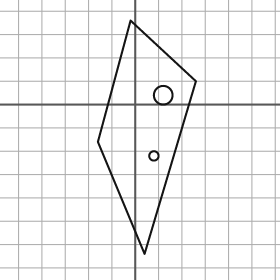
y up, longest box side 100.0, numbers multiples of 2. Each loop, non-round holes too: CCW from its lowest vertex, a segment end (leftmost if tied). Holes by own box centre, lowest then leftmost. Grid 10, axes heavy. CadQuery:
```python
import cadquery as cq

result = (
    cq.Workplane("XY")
    .moveTo(4.0, -64.0)
    .lineTo(26.0, 10.0)
    .lineTo(-2.0, 36.0)
    .lineTo(-16.0, -16.0)
    .close()
    .moveTo(8.0, -22.0)
    .circle(2.0)
    .moveTo(12.0, 4.0)
    .circle(4.0)
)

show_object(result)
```